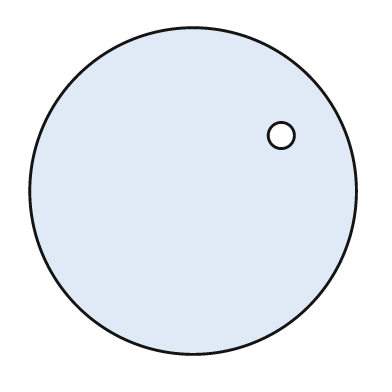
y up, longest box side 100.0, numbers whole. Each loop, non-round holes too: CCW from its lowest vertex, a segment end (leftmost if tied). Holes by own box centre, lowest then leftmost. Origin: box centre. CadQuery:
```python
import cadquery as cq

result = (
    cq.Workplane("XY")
    .moveTo(0.0, 0.0)
    .circle(50.0)
    .moveTo(27.0, 17.0)
    .circle(4.0)
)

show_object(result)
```